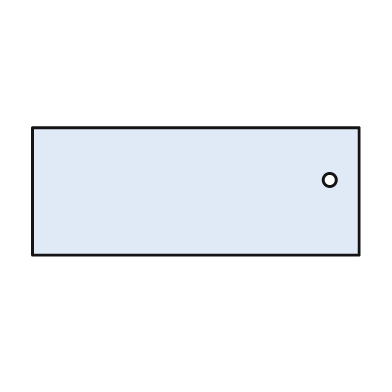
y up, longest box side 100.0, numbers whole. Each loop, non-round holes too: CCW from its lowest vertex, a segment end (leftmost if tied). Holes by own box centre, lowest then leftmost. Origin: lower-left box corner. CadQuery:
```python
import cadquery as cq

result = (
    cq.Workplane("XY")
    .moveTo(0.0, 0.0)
    .lineTo(100.0, 0.0)
    .lineTo(100.0, 39.0)
    .lineTo(0.0, 39.0)
    .close()
    .moveTo(91.0, 23.0)
    .circle(2.0)
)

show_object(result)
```